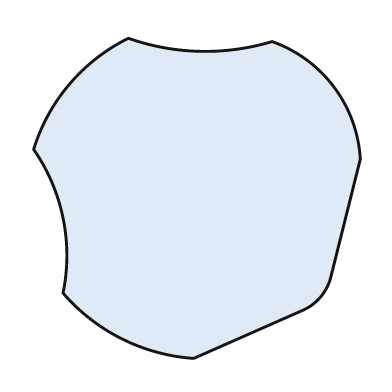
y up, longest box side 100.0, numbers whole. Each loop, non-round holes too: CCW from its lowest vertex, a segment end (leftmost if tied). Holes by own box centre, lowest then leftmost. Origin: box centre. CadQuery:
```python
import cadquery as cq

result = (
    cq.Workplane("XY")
    .moveTo(-1.0, -49.0)
    .lineTo(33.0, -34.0)
    .threePointArc((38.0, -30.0), (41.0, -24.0))
    .lineTo(50.0, 12.0)
    .threePointArc((42.0, 34.0), (23.0, 48.0))
    .threePointArc((1.0, 45.0), (-21.0, 49.0))
    .threePointArc((-39.0, 35.0), (-50.0, 15.0))
    .threePointArc((-41.0, -6.0), (-41.0, -29.0))
    .threePointArc((-23.0, -43.0), (-1.0, -49.0))
    .close()
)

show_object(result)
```